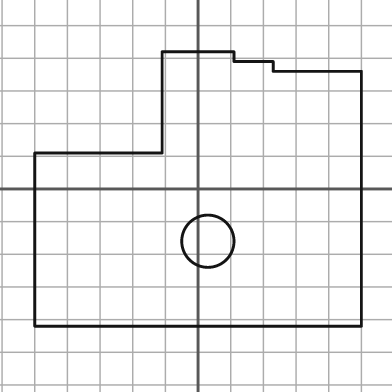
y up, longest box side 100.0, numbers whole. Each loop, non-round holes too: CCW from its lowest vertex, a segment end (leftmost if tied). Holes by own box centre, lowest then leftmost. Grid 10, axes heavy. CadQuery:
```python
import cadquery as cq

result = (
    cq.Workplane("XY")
    .moveTo(-50.0, -42.0)
    .lineTo(50.0, -42.0)
    .lineTo(50.0, 36.0)
    .lineTo(23.0, 36.0)
    .lineTo(23.0, 39.0)
    .lineTo(11.0, 39.0)
    .lineTo(11.0, 42.0)
    .lineTo(-11.0, 42.0)
    .lineTo(-11.0, 11.0)
    .lineTo(-50.0, 11.0)
    .close()
    .moveTo(3.0, -16.0)
    .circle(8.0)
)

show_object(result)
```